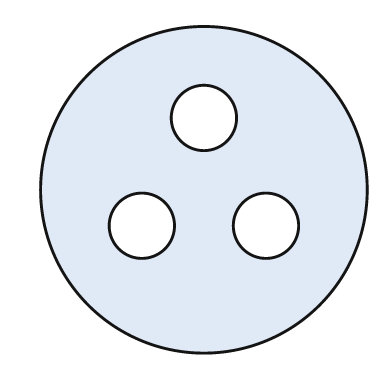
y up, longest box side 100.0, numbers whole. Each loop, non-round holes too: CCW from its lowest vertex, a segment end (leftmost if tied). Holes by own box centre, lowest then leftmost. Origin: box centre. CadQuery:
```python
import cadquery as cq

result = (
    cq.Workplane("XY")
    .moveTo(0.0, 0.0)
    .circle(50.0)
    .moveTo(-19.0, -11.0)
    .circle(10.0)
    .moveTo(19.0, -11.0)
    .circle(10.0)
    .moveTo(0.0, 22.0)
    .circle(10.0)
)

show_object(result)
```